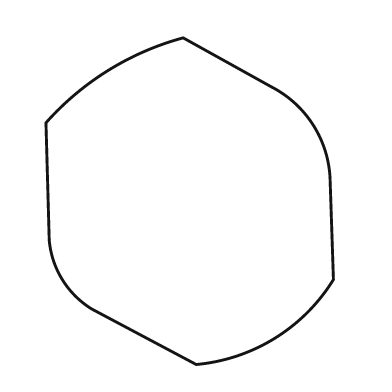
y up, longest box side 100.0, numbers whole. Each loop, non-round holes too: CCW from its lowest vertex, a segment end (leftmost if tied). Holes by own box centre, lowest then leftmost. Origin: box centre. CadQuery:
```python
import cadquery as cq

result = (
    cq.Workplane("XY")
    .moveTo(2.0, -50.0)
    .threePointArc((26.0, -42.0), (44.0, -24.0))
    .lineTo(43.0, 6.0)
    .threePointArc((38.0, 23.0), (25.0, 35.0))
    .lineTo(-2.0, 50.0)
    .threePointArc((-25.0, 40.0), (-44.0, 24.0))
    .lineTo(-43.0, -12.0)
    .threePointArc((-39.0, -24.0), (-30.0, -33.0))
    .close()
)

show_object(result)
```